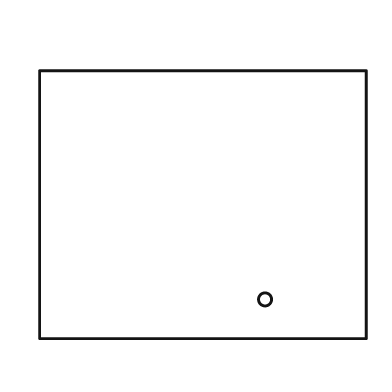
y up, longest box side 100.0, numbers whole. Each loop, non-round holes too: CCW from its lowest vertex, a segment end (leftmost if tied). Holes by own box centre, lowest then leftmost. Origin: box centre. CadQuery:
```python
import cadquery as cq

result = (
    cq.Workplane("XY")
    .moveTo(-50.0, -41.0)
    .lineTo(50.0, -41.0)
    .lineTo(50.0, 41.0)
    .lineTo(-50.0, 41.0)
    .close()
    .moveTo(19.0, -29.0)
    .circle(2.0)
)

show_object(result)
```